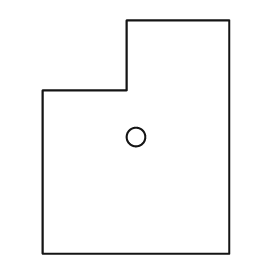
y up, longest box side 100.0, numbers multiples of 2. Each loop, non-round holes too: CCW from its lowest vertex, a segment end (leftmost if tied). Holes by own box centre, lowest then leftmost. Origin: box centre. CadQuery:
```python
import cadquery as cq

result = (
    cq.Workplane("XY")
    .moveTo(-40.0, -50.0)
    .lineTo(40.0, -50.0)
    .lineTo(40.0, 50.0)
    .lineTo(-4.0, 50.0)
    .lineTo(-4.0, 20.0)
    .lineTo(-40.0, 20.0)
    .close()
    .moveTo(0.0, 0.0)
    .circle(4.0)
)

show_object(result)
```